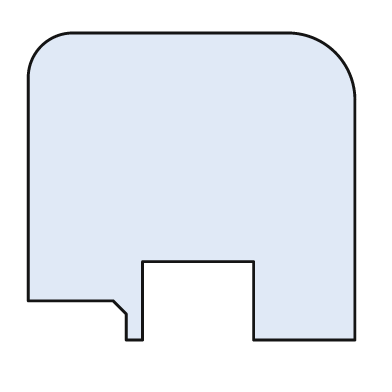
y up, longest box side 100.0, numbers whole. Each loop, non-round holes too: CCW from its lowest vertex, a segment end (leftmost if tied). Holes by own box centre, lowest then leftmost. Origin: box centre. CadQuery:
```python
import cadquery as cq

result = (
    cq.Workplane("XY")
    .moveTo(-20.0, -47.0)
    .lineTo(-15.0, -47.0)
    .lineTo(-15.0, -23.0)
    .lineTo(19.0, -23.0)
    .lineTo(19.0, -47.0)
    .lineTo(50.0, -47.0)
    .lineTo(50.0, 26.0)
    .threePointArc((44.0, 41.0), (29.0, 47.0))
    .lineTo(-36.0, 47.0)
    .threePointArc((-46.0, 43.0), (-50.0, 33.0))
    .lineTo(-50.0, -35.0)
    .lineTo(-24.0, -35.0)
    .lineTo(-20.0, -39.0)
    .close()
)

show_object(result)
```